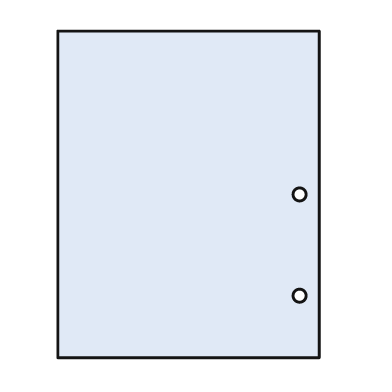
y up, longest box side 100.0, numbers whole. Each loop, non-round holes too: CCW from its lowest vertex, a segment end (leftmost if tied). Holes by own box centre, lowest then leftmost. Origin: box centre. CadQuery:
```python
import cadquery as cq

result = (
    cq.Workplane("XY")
    .moveTo(-40.0, -50.0)
    .lineTo(40.0, -50.0)
    .lineTo(40.0, 50.0)
    .lineTo(-40.0, 50.0)
    .close()
    .moveTo(34.0, -31.0)
    .circle(2.0)
    .moveTo(34.0, 0.0)
    .circle(2.0)
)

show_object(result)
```